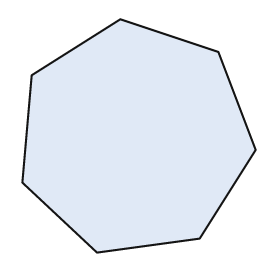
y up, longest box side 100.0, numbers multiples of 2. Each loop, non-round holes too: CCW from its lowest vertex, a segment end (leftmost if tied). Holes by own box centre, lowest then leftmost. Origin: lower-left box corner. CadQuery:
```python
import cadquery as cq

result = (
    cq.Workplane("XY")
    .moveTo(32.0, 0.0)
    .lineTo(76.0, 6.0)
    .lineTo(100.0, 44.0)
    .lineTo(84.0, 86.0)
    .lineTo(42.0, 100.0)
    .lineTo(4.0, 76.0)
    .lineTo(0.0, 30.0)
    .close()
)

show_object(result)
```